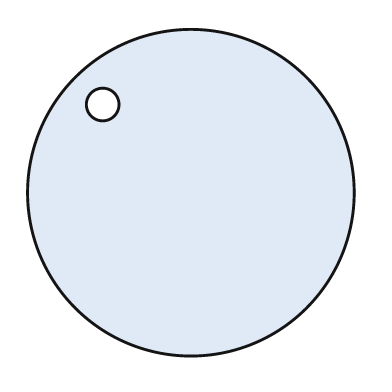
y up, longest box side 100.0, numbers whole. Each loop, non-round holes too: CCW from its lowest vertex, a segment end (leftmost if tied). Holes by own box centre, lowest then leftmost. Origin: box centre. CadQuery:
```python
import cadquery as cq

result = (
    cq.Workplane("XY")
    .moveTo(0.0, 0.0)
    .circle(50.0)
    .moveTo(-27.0, 27.0)
    .circle(5.0)
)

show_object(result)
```